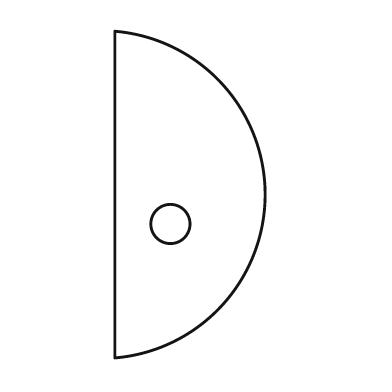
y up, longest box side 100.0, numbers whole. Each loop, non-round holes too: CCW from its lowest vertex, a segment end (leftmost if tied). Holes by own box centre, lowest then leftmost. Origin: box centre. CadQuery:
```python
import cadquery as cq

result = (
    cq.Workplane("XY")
    .moveTo(-23.0, -50.0)
    .threePointArc((23.0, 0.0), (-23.0, 50.0))
    .close()
    .moveTo(-6.0, -9.0)
    .circle(6.0)
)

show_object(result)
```